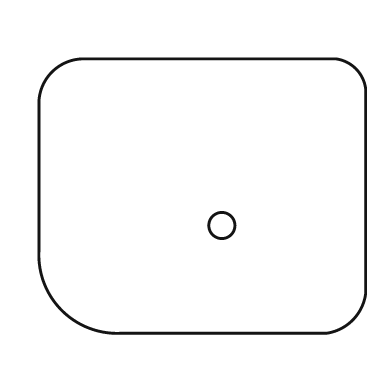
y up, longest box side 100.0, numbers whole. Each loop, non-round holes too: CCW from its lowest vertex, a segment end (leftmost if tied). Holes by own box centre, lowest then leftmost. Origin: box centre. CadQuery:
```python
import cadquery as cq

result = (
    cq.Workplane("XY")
    .moveTo(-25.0, -42.0)
    .lineTo(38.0, -42.0)
    .threePointArc((46.0, -38.0), (50.0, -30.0))
    .lineTo(50.0, 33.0)
    .threePointArc((47.0, 39.0), (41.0, 42.0))
    .lineTo(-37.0, 42.0)
    .threePointArc((-46.0, 38.0), (-50.0, 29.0))
    .lineTo(-50.0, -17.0)
    .threePointArc((-43.0, -35.0), (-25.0, -42.0))
    .close()
    .moveTo(6.0, -9.0)
    .circle(4.0)
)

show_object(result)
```